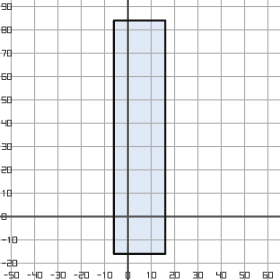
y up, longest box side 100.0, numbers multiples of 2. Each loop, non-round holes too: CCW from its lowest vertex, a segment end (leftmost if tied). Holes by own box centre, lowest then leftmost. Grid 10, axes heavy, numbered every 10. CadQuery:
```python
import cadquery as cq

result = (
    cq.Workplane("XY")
    .moveTo(-6.0, -16.0)
    .lineTo(16.0, -16.0)
    .lineTo(16.0, 84.0)
    .lineTo(-6.0, 84.0)
    .close()
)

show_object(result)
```